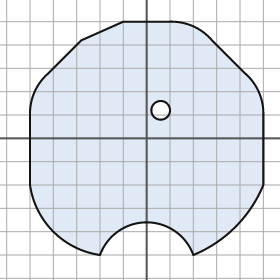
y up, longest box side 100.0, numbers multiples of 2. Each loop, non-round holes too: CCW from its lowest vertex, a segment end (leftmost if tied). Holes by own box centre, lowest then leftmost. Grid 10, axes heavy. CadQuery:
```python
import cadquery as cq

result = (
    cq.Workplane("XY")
    .moveTo(-20.0, -50.0)
    .threePointArc((0.0, -36.0), (20.0, -50.0))
    .threePointArc((38.0, -38.0), (50.0, -20.0))
    .lineTo(50.0, 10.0)
    .threePointArc((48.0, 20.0), (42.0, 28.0))
    .lineTo(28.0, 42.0)
    .threePointArc((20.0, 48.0), (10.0, 50.0))
    .lineTo(-10.0, 50.0)
    .lineTo(-28.0, 42.0)
    .lineTo(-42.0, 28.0)
    .threePointArc((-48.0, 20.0), (-50.0, 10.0))
    .lineTo(-50.0, -20.0)
    .threePointArc((-40.0, -40.0), (-20.0, -50.0))
    .close()
    .moveTo(6.0, 12.0)
    .circle(4.0)
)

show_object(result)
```